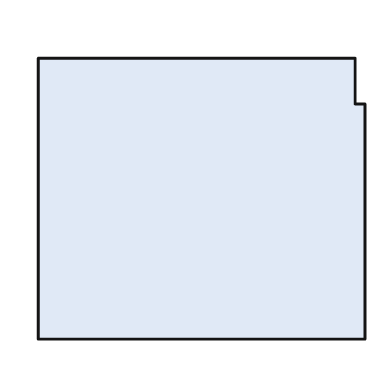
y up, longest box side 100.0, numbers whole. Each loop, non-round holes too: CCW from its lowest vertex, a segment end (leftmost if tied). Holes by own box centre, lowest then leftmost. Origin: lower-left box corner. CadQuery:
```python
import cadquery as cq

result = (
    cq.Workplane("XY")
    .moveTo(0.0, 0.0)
    .lineTo(100.0, 0.0)
    .lineTo(100.0, 72.0)
    .lineTo(97.0, 72.0)
    .lineTo(97.0, 86.0)
    .lineTo(0.0, 86.0)
    .close()
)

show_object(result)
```